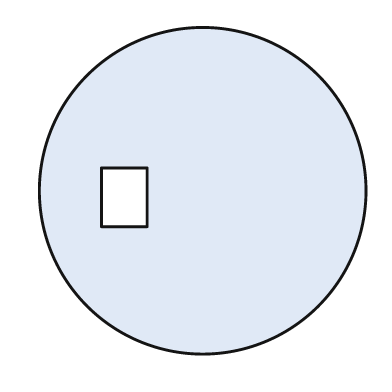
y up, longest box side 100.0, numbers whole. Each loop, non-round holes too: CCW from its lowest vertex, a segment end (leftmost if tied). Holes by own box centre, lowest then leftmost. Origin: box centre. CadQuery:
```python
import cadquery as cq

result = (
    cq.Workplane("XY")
    .moveTo(0.0, 0.0)
    .circle(50.0)
    .moveTo(-31.0, -11.0)
    .lineTo(-17.0, -11.0)
    .lineTo(-17.0, 7.0)
    .lineTo(-31.0, 7.0)
    .close()
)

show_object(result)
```